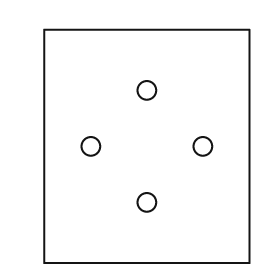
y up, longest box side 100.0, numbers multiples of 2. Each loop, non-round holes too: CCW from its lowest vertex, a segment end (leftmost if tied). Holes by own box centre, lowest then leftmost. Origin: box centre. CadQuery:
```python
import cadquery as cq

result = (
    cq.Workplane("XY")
    .moveTo(-44.0, -50.0)
    .lineTo(44.0, -50.0)
    .lineTo(44.0, 50.0)
    .lineTo(-44.0, 50.0)
    .close()
    .moveTo(0.0, -24.0)
    .circle(4.0)
    .moveTo(-24.0, 0.0)
    .circle(4.0)
    .moveTo(24.0, 0.0)
    .circle(4.0)
    .moveTo(0.0, 24.0)
    .circle(4.0)
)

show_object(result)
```